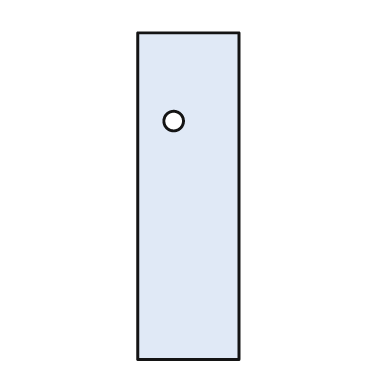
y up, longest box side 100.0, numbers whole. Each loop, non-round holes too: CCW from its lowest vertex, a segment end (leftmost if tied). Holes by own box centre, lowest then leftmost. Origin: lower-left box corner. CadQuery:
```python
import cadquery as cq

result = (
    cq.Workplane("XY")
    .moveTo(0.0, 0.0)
    .lineTo(31.0, 0.0)
    .lineTo(31.0, 100.0)
    .lineTo(0.0, 100.0)
    .close()
    .moveTo(11.0, 73.0)
    .circle(3.0)
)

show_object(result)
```